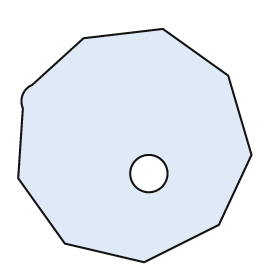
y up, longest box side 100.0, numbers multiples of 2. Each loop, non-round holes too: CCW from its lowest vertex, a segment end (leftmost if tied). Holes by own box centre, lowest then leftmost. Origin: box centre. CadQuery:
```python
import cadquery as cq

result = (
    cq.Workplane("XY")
    .moveTo(4.0, -50.0)
    .lineTo(36.0, -34.0)
    .lineTo(50.0, -4.0)
    .lineTo(40.0, 30.0)
    .lineTo(12.0, 50.0)
    .lineTo(-22.0, 46.0)
    .lineTo(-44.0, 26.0)
    .threePointArc((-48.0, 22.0), (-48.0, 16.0))
    .lineTo(-50.0, -14.0)
    .lineTo(-30.0, -42.0)
    .close()
    .moveTo(6.0, -12.0)
    .circle(8.0)
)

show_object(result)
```